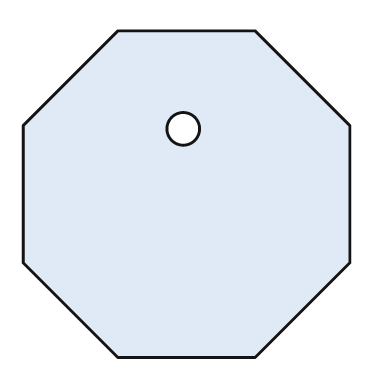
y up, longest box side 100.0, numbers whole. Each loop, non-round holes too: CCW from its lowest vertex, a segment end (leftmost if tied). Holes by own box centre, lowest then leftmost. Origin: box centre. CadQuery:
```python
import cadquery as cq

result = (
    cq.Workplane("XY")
    .moveTo(-21.0, -50.0)
    .lineTo(21.0, -50.0)
    .lineTo(50.0, -21.0)
    .lineTo(50.0, 21.0)
    .lineTo(21.0, 50.0)
    .lineTo(-21.0, 50.0)
    .lineTo(-50.0, 21.0)
    .lineTo(-50.0, -21.0)
    .close()
    .moveTo(-1.0, 20.0)
    .circle(5.0)
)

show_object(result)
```